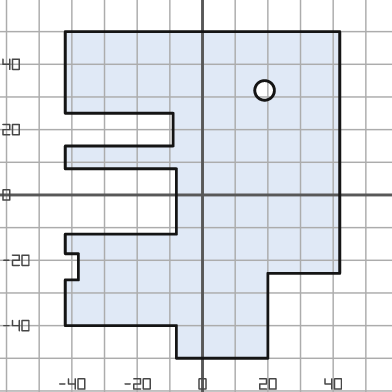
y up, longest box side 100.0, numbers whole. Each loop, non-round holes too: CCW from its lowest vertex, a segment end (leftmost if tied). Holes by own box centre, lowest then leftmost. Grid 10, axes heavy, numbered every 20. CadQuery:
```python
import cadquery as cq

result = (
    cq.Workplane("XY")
    .moveTo(-8.0, -50.0)
    .lineTo(20.0, -50.0)
    .lineTo(20.0, -24.0)
    .lineTo(42.0, -24.0)
    .lineTo(42.0, 50.0)
    .lineTo(-42.0, 50.0)
    .lineTo(-42.0, 25.0)
    .lineTo(-9.0, 25.0)
    .lineTo(-9.0, 15.0)
    .lineTo(-42.0, 15.0)
    .lineTo(-42.0, 8.0)
    .lineTo(-8.0, 8.0)
    .lineTo(-8.0, -12.0)
    .lineTo(-42.0, -12.0)
    .lineTo(-42.0, -18.0)
    .lineTo(-38.0, -18.0)
    .lineTo(-38.0, -26.0)
    .lineTo(-42.0, -26.0)
    .lineTo(-42.0, -40.0)
    .lineTo(-8.0, -40.0)
    .close()
    .moveTo(19.0, 32.0)
    .circle(3.0)
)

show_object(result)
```